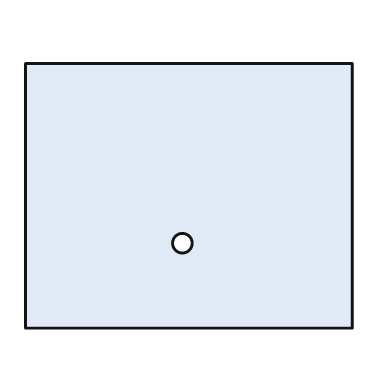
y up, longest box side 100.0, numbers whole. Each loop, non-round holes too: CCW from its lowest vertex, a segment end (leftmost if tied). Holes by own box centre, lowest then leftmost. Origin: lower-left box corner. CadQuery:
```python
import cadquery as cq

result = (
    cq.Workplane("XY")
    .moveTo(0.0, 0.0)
    .lineTo(100.0, 0.0)
    .lineTo(100.0, 81.0)
    .lineTo(0.0, 81.0)
    .close()
    .moveTo(48.0, 26.0)
    .circle(3.0)
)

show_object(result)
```